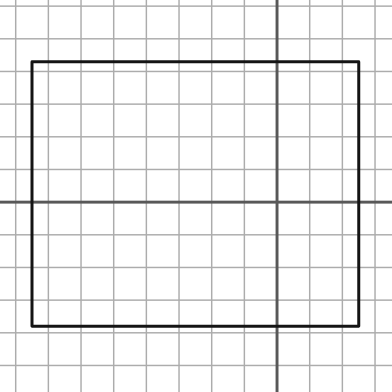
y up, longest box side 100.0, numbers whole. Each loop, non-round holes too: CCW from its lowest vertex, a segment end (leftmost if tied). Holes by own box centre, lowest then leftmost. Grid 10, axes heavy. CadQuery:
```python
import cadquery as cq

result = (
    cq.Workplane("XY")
    .moveTo(-75.0, -38.0)
    .lineTo(25.0, -38.0)
    .lineTo(25.0, 43.0)
    .lineTo(-75.0, 43.0)
    .close()
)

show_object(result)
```